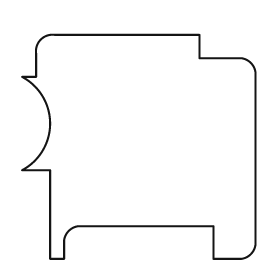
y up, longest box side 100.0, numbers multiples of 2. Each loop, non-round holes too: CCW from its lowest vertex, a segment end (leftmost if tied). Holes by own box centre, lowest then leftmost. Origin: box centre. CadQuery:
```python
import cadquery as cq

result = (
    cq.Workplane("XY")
    .moveTo(-38.0, -48.0)
    .lineTo(-32.0, -48.0)
    .lineTo(-32.0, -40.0)
    .threePointArc((-30.0, -36.0), (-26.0, -34.0))
    .lineTo(32.0, -34.0)
    .lineTo(32.0, -48.0)
    .lineTo(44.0, -48.0)
    .threePointArc((48.0, -46.0), (50.0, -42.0))
    .lineTo(50.0, 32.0)
    .threePointArc((48.0, 36.0), (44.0, 38.0))
    .lineTo(26.0, 38.0)
    .lineTo(26.0, 48.0)
    .lineTo(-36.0, 48.0)
    .threePointArc((-42.0, 46.0), (-44.0, 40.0))
    .lineTo(-44.0, 30.0)
    .lineTo(-50.0, 30.0)
    .threePointArc((-38.0, 10.0), (-50.0, -10.0))
    .lineTo(-38.0, -10.0)
    .close()
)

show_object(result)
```